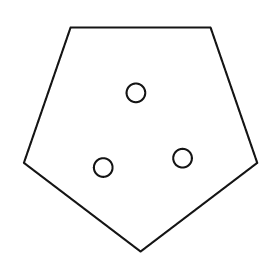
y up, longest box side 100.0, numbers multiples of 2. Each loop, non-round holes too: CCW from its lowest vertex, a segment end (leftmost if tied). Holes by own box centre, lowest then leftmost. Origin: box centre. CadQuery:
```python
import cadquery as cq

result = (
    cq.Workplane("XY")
    .moveTo(0.0, -48.0)
    .lineTo(50.0, -10.0)
    .lineTo(30.0, 48.0)
    .lineTo(-30.0, 48.0)
    .lineTo(-50.0, -10.0)
    .close()
    .moveTo(-16.0, -12.0)
    .circle(4.0)
    .moveTo(18.0, -8.0)
    .circle(4.0)
    .moveTo(-2.0, 20.0)
    .circle(4.0)
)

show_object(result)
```